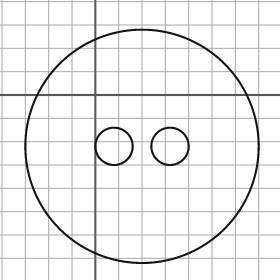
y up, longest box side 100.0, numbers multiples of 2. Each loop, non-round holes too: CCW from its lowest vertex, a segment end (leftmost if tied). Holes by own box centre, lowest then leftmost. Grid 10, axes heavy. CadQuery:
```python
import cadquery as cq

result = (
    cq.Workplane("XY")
    .moveTo(20.0, -22.0)
    .circle(50.0)
    .moveTo(8.0, -22.0)
    .circle(8.0)
    .moveTo(32.0, -22.0)
    .circle(8.0)
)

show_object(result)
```